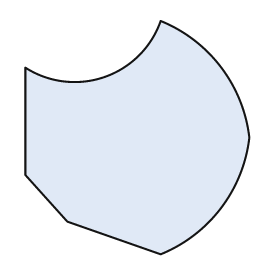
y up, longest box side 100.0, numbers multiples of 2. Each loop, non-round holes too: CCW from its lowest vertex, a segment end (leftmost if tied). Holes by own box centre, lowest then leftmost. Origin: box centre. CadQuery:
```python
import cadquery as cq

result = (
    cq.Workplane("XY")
    .moveTo(10.0, -50.0)
    .threePointArc((36.0, -30.0), (48.0, 0.0))
    .threePointArc((36.0, 30.0), (10.0, 50.0))
    .threePointArc((-14.0, 26.0), (-48.0, 30.0))
    .lineTo(-48.0, -16.0)
    .lineTo(-30.0, -36.0)
    .close()
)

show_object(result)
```